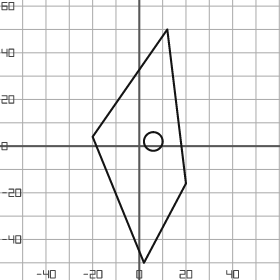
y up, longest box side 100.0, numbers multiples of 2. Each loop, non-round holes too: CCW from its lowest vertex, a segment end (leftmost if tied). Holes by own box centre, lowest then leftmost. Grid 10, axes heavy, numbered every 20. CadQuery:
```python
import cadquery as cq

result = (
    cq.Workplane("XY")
    .moveTo(2.0, -50.0)
    .lineTo(20.0, -16.0)
    .lineTo(12.0, 50.0)
    .lineTo(-20.0, 4.0)
    .close()
    .moveTo(6.0, 2.0)
    .circle(4.0)
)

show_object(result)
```